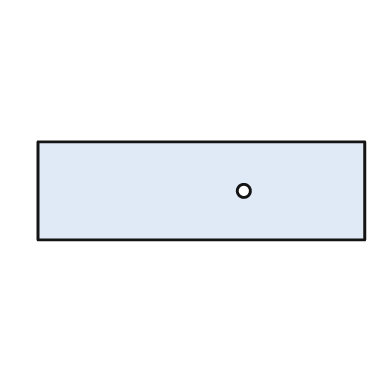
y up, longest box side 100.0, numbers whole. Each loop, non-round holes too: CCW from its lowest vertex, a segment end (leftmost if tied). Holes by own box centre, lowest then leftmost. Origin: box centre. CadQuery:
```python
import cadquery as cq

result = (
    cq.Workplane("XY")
    .moveTo(-50.0, -15.0)
    .lineTo(50.0, -15.0)
    .lineTo(50.0, 15.0)
    .lineTo(-50.0, 15.0)
    .close()
    .moveTo(13.0, 0.0)
    .circle(2.0)
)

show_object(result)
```